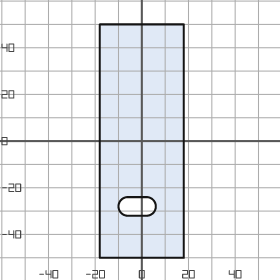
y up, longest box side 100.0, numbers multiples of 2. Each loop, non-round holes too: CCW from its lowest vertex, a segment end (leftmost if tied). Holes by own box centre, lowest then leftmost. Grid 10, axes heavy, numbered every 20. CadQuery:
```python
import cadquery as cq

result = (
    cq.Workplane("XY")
    .moveTo(-18.0, -50.0)
    .lineTo(18.0, -50.0)
    .lineTo(18.0, 50.0)
    .lineTo(-18.0, 50.0)
    .close()
    .moveTo(-6.0, -32.0)
    .lineTo(2.0, -32.0)
    .threePointArc((6.0, -28.0), (2.0, -24.0))
    .lineTo(-6.0, -24.0)
    .threePointArc((-10.0, -28.0), (-6.0, -32.0))
    .close()
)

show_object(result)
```